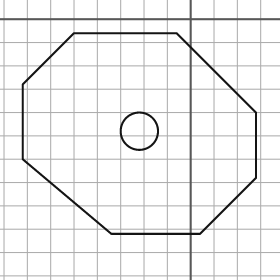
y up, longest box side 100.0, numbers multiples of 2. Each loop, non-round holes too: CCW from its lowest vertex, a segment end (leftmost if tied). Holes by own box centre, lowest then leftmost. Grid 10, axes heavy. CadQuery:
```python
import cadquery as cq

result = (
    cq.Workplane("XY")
    .moveTo(-34.0, -92.0)
    .lineTo(4.0, -92.0)
    .lineTo(28.0, -68.0)
    .lineTo(28.0, -40.0)
    .lineTo(-6.0, -6.0)
    .lineTo(-50.0, -6.0)
    .lineTo(-72.0, -28.0)
    .lineTo(-72.0, -60.0)
    .close()
    .moveTo(-22.0, -48.0)
    .circle(8.0)
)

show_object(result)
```